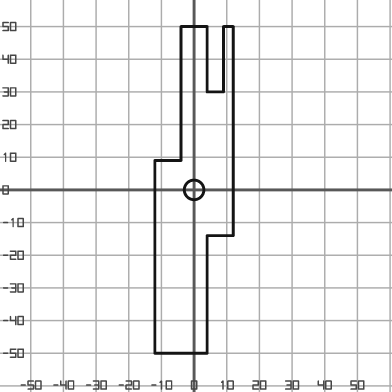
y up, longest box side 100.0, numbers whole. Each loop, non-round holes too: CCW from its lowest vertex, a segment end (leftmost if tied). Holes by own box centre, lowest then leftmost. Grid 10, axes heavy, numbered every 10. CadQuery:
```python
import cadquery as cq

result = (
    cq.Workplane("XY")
    .moveTo(-12.0, -50.0)
    .lineTo(4.0, -50.0)
    .lineTo(4.0, -14.0)
    .lineTo(12.0, -14.0)
    .lineTo(12.0, 50.0)
    .lineTo(9.0, 50.0)
    .lineTo(9.0, 30.0)
    .lineTo(4.0, 30.0)
    .lineTo(4.0, 50.0)
    .lineTo(-4.0, 50.0)
    .lineTo(-4.0, 9.0)
    .lineTo(-12.0, 9.0)
    .close()
    .moveTo(0.0, 0.0)
    .circle(3.0)
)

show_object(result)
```